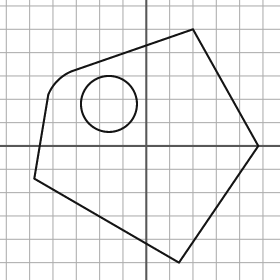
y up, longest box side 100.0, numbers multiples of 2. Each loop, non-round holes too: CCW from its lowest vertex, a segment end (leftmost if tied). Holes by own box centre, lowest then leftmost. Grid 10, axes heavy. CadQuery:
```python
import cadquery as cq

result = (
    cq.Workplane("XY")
    .moveTo(14.0, -50.0)
    .lineTo(48.0, 0.0)
    .lineTo(20.0, 50.0)
    .lineTo(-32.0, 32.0)
    .threePointArc((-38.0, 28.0), (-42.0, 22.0))
    .lineTo(-48.0, -14.0)
    .close()
    .moveTo(-16.0, 18.0)
    .circle(12.0)
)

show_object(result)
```